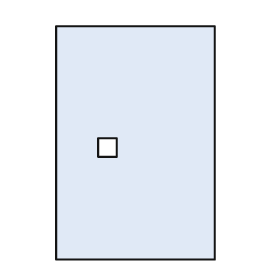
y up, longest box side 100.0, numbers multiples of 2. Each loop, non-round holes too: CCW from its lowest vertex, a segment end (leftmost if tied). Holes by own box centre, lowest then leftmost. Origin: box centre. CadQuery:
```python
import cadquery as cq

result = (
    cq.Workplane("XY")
    .moveTo(-34.0, -50.0)
    .lineTo(34.0, -50.0)
    .lineTo(34.0, 50.0)
    .lineTo(-34.0, 50.0)
    .close()
    .moveTo(-16.0, -6.0)
    .lineTo(-8.0, -6.0)
    .lineTo(-8.0, 2.0)
    .lineTo(-16.0, 2.0)
    .close()
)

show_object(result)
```